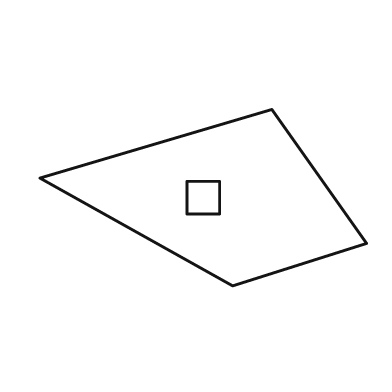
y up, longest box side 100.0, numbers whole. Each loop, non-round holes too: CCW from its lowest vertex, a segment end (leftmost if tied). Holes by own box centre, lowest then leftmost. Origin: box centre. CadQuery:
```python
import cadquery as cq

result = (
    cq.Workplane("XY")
    .moveTo(9.0, -27.0)
    .lineTo(50.0, -14.0)
    .lineTo(21.0, 27.0)
    .lineTo(-50.0, 6.0)
    .close()
    .moveTo(-5.0, -5.0)
    .lineTo(5.0, -5.0)
    .lineTo(5.0, 5.0)
    .lineTo(-5.0, 5.0)
    .close()
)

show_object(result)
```